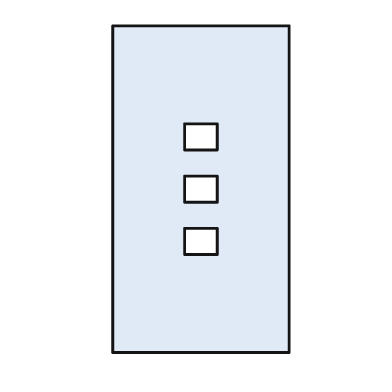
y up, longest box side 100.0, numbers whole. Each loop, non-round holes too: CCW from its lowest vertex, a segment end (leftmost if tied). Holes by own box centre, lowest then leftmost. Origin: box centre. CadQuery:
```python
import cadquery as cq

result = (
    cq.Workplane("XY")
    .moveTo(-27.0, -50.0)
    .lineTo(27.0, -50.0)
    .lineTo(27.0, 50.0)
    .lineTo(-27.0, 50.0)
    .close()
    .moveTo(-5.0, -20.0)
    .lineTo(5.0, -20.0)
    .lineTo(5.0, -12.0)
    .lineTo(-5.0, -12.0)
    .close()
    .moveTo(-5.0, -4.0)
    .lineTo(5.0, -4.0)
    .lineTo(5.0, 4.0)
    .lineTo(-5.0, 4.0)
    .close()
    .moveTo(-5.0, 12.0)
    .lineTo(5.0, 12.0)
    .lineTo(5.0, 20.0)
    .lineTo(-5.0, 20.0)
    .close()
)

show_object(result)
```